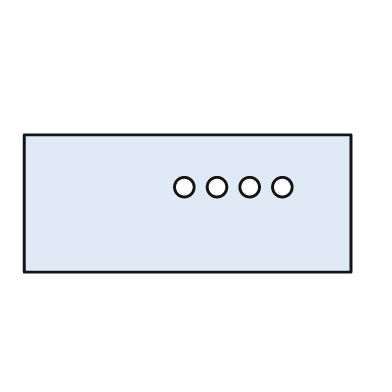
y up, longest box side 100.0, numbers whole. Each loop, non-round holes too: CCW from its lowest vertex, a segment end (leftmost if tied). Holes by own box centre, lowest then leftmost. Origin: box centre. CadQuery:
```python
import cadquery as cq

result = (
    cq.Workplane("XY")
    .moveTo(-50.0, -21.0)
    .lineTo(50.0, -21.0)
    .lineTo(50.0, 21.0)
    .lineTo(-50.0, 21.0)
    .close()
    .moveTo(-1.0, 5.0)
    .circle(3.0)
    .moveTo(9.0, 5.0)
    .circle(3.0)
    .moveTo(19.0, 5.0)
    .circle(3.0)
    .moveTo(29.0, 5.0)
    .circle(3.0)
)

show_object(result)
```